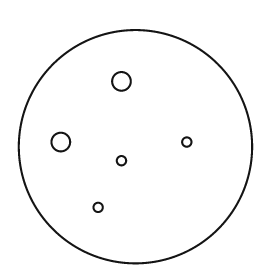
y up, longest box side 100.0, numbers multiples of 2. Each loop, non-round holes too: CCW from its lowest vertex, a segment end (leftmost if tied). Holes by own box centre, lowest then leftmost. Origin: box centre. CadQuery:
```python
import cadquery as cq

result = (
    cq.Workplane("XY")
    .moveTo(0.0, 0.0)
    .circle(50.0)
    .moveTo(-16.0, -26.0)
    .circle(2.0)
    .moveTo(-6.0, -6.0)
    .circle(2.0)
    .moveTo(-32.0, 2.0)
    .circle(4.0)
    .moveTo(22.0, 2.0)
    .circle(2.0)
    .moveTo(-6.0, 28.0)
    .circle(4.0)
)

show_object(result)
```